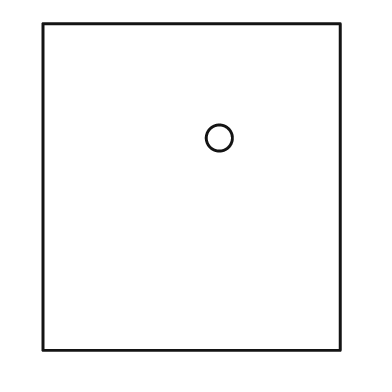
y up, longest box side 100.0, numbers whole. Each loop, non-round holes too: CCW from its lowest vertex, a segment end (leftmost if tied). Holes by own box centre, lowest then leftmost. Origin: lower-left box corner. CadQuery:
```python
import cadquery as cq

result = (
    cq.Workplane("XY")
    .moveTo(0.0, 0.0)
    .lineTo(91.0, 0.0)
    .lineTo(91.0, 100.0)
    .lineTo(0.0, 100.0)
    .close()
    .moveTo(54.0, 65.0)
    .circle(4.0)
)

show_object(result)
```